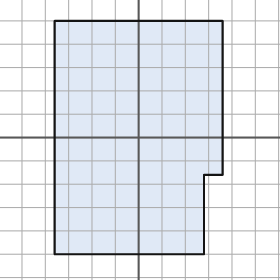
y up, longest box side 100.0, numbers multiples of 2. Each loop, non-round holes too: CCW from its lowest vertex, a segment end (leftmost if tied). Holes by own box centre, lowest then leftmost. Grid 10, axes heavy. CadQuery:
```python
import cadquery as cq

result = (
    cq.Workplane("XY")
    .moveTo(-36.0, -50.0)
    .lineTo(28.0, -50.0)
    .lineTo(28.0, -16.0)
    .lineTo(36.0, -16.0)
    .lineTo(36.0, 50.0)
    .lineTo(-36.0, 50.0)
    .close()
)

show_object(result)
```